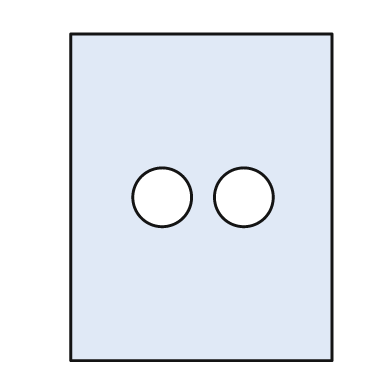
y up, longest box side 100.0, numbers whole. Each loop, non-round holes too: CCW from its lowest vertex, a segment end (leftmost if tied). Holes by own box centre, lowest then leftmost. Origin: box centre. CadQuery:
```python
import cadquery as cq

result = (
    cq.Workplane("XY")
    .moveTo(-40.0, -50.0)
    .lineTo(40.0, -50.0)
    .lineTo(40.0, 50.0)
    .lineTo(-40.0, 50.0)
    .close()
    .moveTo(-12.0, 0.0)
    .circle(9.0)
    .moveTo(13.0, 0.0)
    .circle(9.0)
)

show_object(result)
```